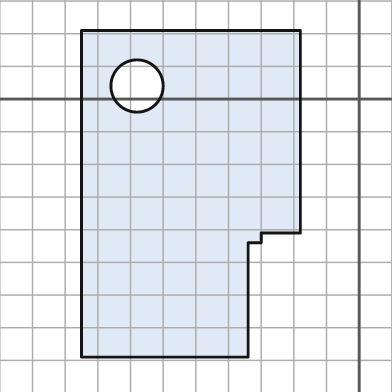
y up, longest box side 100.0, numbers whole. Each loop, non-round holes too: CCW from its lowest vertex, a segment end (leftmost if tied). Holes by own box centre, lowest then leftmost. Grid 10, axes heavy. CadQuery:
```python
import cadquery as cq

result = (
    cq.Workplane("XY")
    .moveTo(-85.0, -79.0)
    .lineTo(-34.0, -79.0)
    .lineTo(-34.0, -44.0)
    .lineTo(-30.0, -44.0)
    .lineTo(-30.0, -41.0)
    .lineTo(-18.0, -41.0)
    .lineTo(-18.0, 21.0)
    .lineTo(-85.0, 21.0)
    .close()
    .moveTo(-68.0, 4.0)
    .circle(8.0)
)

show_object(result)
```